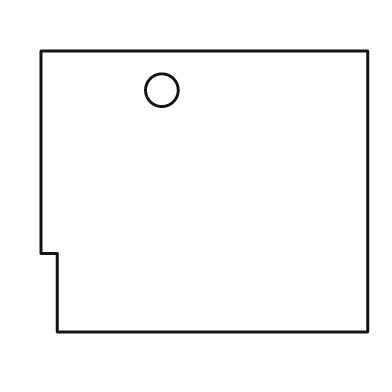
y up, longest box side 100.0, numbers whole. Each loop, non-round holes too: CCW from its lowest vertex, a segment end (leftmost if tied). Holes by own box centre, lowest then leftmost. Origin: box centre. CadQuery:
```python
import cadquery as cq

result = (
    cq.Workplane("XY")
    .moveTo(-45.0, -43.0)
    .lineTo(50.0, -43.0)
    .lineTo(50.0, 43.0)
    .lineTo(-50.0, 43.0)
    .lineTo(-50.0, -19.0)
    .lineTo(-45.0, -19.0)
    .close()
    .moveTo(-13.0, 31.0)
    .circle(5.0)
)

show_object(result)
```